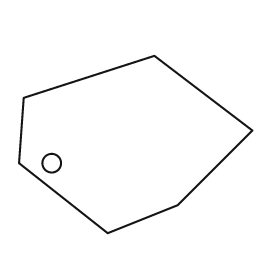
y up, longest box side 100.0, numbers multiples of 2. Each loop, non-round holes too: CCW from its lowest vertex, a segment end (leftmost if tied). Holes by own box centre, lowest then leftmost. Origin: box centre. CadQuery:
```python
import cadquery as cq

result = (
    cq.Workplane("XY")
    .moveTo(-12.0, -38.0)
    .lineTo(18.0, -26.0)
    .lineTo(50.0, 6.0)
    .lineTo(8.0, 38.0)
    .lineTo(-48.0, 20.0)
    .lineTo(-50.0, -8.0)
    .close()
    .moveTo(-36.0, -8.0)
    .circle(4.0)
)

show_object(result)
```